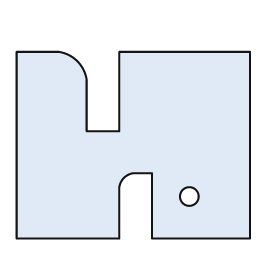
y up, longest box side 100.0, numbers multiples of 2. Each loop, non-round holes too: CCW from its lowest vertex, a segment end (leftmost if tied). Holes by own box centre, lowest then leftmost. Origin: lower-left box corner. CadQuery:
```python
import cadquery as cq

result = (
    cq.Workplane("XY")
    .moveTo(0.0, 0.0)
    .lineTo(44.0, 0.0)
    .lineTo(44.0, 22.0)
    .threePointArc((46.0, 26.0), (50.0, 28.0))
    .lineTo(58.0, 28.0)
    .lineTo(58.0, 0.0)
    .lineTo(100.0, 0.0)
    .lineTo(100.0, 80.0)
    .lineTo(44.0, 80.0)
    .lineTo(44.0, 46.0)
    .lineTo(30.0, 46.0)
    .lineTo(30.0, 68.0)
    .threePointArc((26.0, 76.0), (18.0, 80.0))
    .lineTo(0.0, 80.0)
    .close()
    .moveTo(74.0, 18.0)
    .circle(4.0)
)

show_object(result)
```